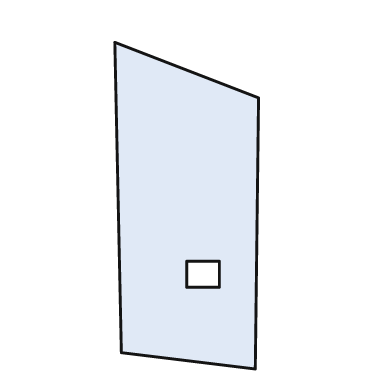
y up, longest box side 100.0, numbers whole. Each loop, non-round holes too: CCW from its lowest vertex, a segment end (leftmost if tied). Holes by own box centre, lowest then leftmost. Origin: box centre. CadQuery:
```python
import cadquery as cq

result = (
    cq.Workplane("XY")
    .moveTo(21.0, -50.0)
    .lineTo(22.0, 33.0)
    .lineTo(-22.0, 50.0)
    .lineTo(-20.0, -45.0)
    .close()
    .moveTo(0.0, -25.0)
    .lineTo(10.0, -25.0)
    .lineTo(10.0, -17.0)
    .lineTo(0.0, -17.0)
    .close()
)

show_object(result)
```